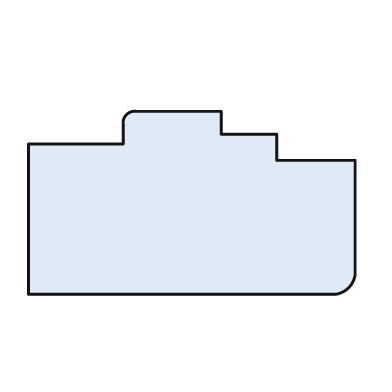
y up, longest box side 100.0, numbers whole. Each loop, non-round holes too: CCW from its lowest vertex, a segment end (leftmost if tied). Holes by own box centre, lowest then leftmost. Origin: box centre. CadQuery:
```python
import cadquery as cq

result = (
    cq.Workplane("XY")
    .moveTo(-50.0, -28.0)
    .lineTo(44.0, -28.0)
    .threePointArc((48.0, -26.0), (50.0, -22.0))
    .lineTo(50.0, 13.0)
    .lineTo(26.0, 13.0)
    .lineTo(26.0, 21.0)
    .lineTo(9.0, 21.0)
    .lineTo(9.0, 28.0)
    .lineTo(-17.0, 28.0)
    .threePointArc((-20.0, 27.0), (-21.0, 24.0))
    .lineTo(-21.0, 18.0)
    .lineTo(-50.0, 18.0)
    .close()
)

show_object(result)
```